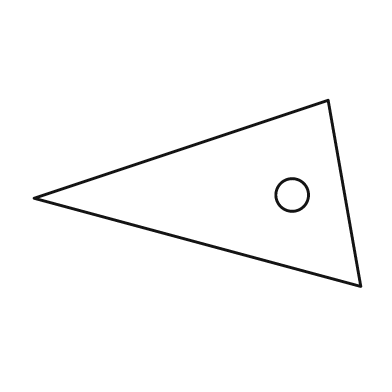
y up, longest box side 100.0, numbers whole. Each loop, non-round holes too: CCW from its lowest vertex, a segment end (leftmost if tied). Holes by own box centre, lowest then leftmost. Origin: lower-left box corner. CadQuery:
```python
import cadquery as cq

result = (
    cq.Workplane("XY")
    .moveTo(100.0, 0.0)
    .lineTo(90.0, 57.0)
    .lineTo(0.0, 27.0)
    .close()
    .moveTo(79.0, 28.0)
    .circle(5.0)
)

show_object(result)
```